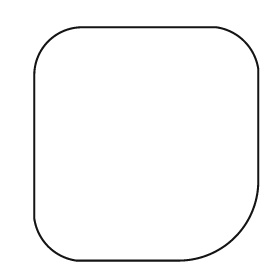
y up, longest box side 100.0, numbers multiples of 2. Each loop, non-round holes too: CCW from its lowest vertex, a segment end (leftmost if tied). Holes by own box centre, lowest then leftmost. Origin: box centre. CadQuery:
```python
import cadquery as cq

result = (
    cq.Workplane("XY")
    .moveTo(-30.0, -50.0)
    .lineTo(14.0, -50.0)
    .threePointArc((38.0, -40.0), (48.0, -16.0))
    .lineTo(48.0, 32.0)
    .threePointArc((42.0, 44.0), (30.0, 50.0))
    .lineTo(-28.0, 50.0)
    .threePointArc((-42.0, 44.0), (-48.0, 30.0))
    .lineTo(-48.0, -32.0)
    .threePointArc((-42.0, -44.0), (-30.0, -50.0))
    .close()
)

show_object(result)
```